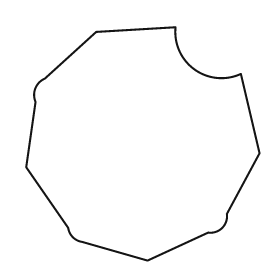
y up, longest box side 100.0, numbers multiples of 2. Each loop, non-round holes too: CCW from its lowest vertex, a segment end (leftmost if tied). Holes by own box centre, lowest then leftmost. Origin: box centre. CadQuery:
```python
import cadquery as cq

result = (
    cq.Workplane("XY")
    .moveTo(2.0, -50.0)
    .lineTo(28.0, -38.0)
    .threePointArc((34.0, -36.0), (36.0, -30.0))
    .lineTo(50.0, -4.0)
    .lineTo(42.0, 30.0)
    .threePointArc((22.0, 32.0), (14.0, 50.0))
    .lineTo(-20.0, 48.0)
    .lineTo(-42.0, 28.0)
    .threePointArc((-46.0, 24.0), (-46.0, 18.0))
    .lineTo(-50.0, -10.0)
    .lineTo(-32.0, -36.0)
    .threePointArc((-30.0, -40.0), (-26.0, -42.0))
    .close()
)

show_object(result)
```